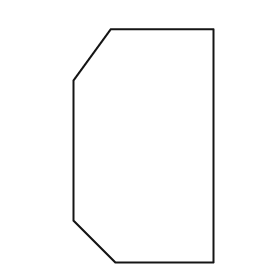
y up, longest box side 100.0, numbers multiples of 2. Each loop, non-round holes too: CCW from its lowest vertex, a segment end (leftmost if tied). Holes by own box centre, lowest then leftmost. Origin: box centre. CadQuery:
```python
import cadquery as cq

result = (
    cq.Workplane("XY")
    .moveTo(-12.0, -50.0)
    .lineTo(30.0, -50.0)
    .lineTo(30.0, 50.0)
    .lineTo(-14.0, 50.0)
    .lineTo(-30.0, 28.0)
    .lineTo(-30.0, -32.0)
    .close()
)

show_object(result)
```